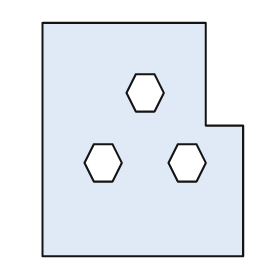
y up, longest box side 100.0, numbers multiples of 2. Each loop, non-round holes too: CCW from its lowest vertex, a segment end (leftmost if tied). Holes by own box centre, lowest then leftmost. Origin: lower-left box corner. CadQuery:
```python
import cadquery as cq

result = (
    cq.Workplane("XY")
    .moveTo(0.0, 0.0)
    .lineTo(86.0, 0.0)
    .lineTo(86.0, 56.0)
    .lineTo(70.0, 56.0)
    .lineTo(70.0, 100.0)
    .lineTo(0.0, 100.0)
    .close()
    .moveTo(22.0, 32.0)
    .lineTo(30.0, 32.0)
    .lineTo(34.0, 40.0)
    .lineTo(30.0, 48.0)
    .lineTo(22.0, 48.0)
    .lineTo(18.0, 40.0)
    .close()
    .moveTo(58.0, 32.0)
    .lineTo(66.0, 32.0)
    .lineTo(70.0, 40.0)
    .lineTo(66.0, 48.0)
    .lineTo(58.0, 48.0)
    .lineTo(54.0, 40.0)
    .close()
    .moveTo(40.0, 62.0)
    .lineTo(48.0, 62.0)
    .lineTo(52.0, 70.0)
    .lineTo(48.0, 78.0)
    .lineTo(40.0, 78.0)
    .lineTo(36.0, 70.0)
    .close()
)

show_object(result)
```